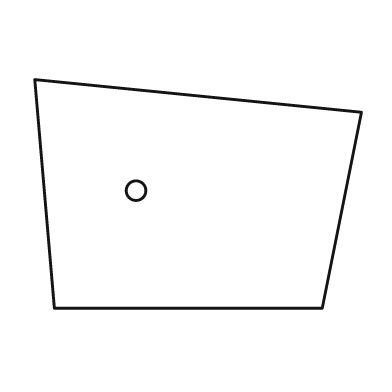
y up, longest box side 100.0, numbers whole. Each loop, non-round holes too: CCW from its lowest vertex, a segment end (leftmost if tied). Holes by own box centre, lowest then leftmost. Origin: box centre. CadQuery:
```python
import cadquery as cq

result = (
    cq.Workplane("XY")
    .moveTo(-44.0, -35.0)
    .lineTo(38.0, -35.0)
    .lineTo(50.0, 25.0)
    .lineTo(-50.0, 35.0)
    .close()
    .moveTo(-19.0, 1.0)
    .circle(3.0)
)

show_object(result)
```